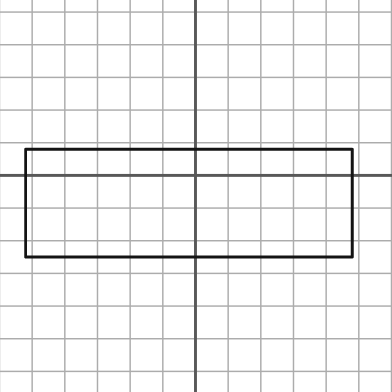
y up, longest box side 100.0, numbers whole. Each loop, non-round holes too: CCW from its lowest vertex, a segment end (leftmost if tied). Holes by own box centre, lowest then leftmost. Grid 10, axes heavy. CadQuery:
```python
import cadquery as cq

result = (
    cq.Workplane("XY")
    .moveTo(-52.0, -25.0)
    .lineTo(48.0, -25.0)
    .lineTo(48.0, 8.0)
    .lineTo(-52.0, 8.0)
    .close()
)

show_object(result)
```